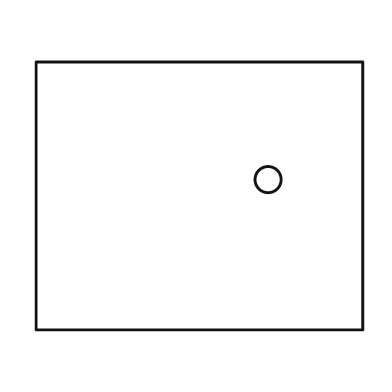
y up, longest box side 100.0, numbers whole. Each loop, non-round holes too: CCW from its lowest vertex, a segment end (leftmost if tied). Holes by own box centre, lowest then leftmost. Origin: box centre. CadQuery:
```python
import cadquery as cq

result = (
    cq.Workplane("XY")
    .moveTo(-50.0, -41.0)
    .lineTo(50.0, -41.0)
    .lineTo(50.0, 41.0)
    .lineTo(-50.0, 41.0)
    .close()
    .moveTo(21.0, 5.0)
    .circle(4.0)
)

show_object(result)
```